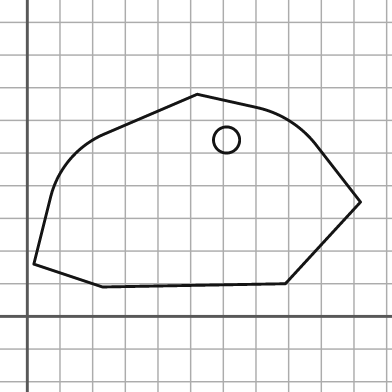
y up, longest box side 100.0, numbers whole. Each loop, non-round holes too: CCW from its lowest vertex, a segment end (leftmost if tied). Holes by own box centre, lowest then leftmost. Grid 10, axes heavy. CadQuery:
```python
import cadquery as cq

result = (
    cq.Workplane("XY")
    .moveTo(23.0, 9.0)
    .lineTo(79.0, 10.0)
    .lineTo(102.0, 35.0)
    .lineTo(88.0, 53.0)
    .threePointArc((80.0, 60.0), (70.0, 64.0))
    .lineTo(52.0, 68.0)
    .lineTo(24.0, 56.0)
    .threePointArc((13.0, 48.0), (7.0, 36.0))
    .lineTo(2.0, 16.0)
    .close()
    .moveTo(61.0, 54.0)
    .circle(4.0)
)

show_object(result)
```